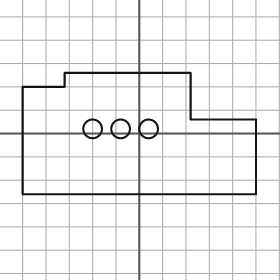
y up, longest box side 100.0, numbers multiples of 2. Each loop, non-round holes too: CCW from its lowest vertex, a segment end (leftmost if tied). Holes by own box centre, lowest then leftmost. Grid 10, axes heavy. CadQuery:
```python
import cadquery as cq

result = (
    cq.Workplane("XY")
    .moveTo(-50.0, -26.0)
    .lineTo(50.0, -26.0)
    .lineTo(50.0, 6.0)
    .lineTo(22.0, 6.0)
    .lineTo(22.0, 26.0)
    .lineTo(-32.0, 26.0)
    .lineTo(-32.0, 20.0)
    .lineTo(-50.0, 20.0)
    .close()
    .moveTo(-20.0, 2.0)
    .circle(4.0)
    .moveTo(-8.0, 2.0)
    .circle(4.0)
    .moveTo(4.0, 2.0)
    .circle(4.0)
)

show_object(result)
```